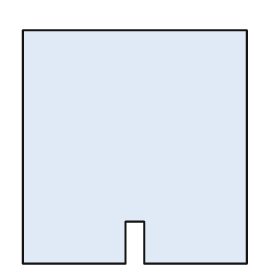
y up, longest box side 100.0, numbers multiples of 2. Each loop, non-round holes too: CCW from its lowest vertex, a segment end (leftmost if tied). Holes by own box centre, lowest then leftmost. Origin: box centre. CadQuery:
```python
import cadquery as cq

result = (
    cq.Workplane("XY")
    .moveTo(-48.0, -50.0)
    .lineTo(-4.0, -50.0)
    .lineTo(-4.0, -32.0)
    .lineTo(4.0, -32.0)
    .lineTo(4.0, -50.0)
    .lineTo(48.0, -50.0)
    .lineTo(48.0, 50.0)
    .lineTo(-48.0, 50.0)
    .close()
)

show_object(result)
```